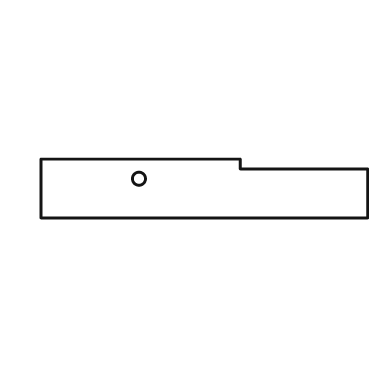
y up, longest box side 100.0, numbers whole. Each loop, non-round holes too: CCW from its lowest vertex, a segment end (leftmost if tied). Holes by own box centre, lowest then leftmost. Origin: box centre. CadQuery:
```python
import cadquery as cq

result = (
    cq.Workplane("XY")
    .moveTo(-50.0, -9.0)
    .lineTo(50.0, -9.0)
    .lineTo(50.0, 6.0)
    .lineTo(11.0, 6.0)
    .lineTo(11.0, 9.0)
    .lineTo(-50.0, 9.0)
    .close()
    .moveTo(-20.0, 3.0)
    .circle(2.0)
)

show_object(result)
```